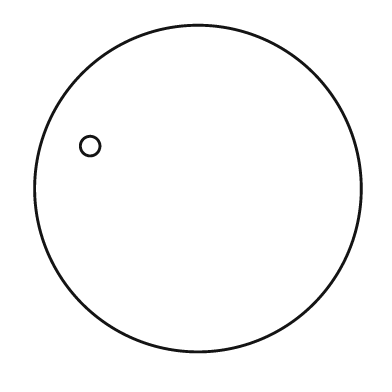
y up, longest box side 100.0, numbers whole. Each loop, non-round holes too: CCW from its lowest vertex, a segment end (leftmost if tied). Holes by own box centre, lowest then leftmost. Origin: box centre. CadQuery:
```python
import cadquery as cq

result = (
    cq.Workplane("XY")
    .moveTo(0.0, 0.0)
    .circle(50.0)
    .moveTo(-33.0, 13.0)
    .circle(3.0)
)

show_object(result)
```